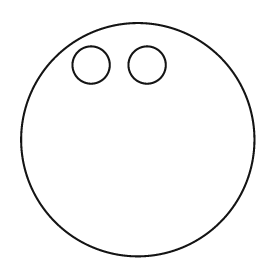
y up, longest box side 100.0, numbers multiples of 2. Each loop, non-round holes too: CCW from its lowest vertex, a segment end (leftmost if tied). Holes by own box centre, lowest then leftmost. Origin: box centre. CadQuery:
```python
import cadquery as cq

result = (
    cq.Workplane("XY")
    .moveTo(0.0, 0.0)
    .circle(50.0)
    .moveTo(-20.0, 32.0)
    .circle(8.0)
    .moveTo(4.0, 32.0)
    .circle(8.0)
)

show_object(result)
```